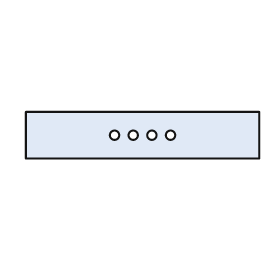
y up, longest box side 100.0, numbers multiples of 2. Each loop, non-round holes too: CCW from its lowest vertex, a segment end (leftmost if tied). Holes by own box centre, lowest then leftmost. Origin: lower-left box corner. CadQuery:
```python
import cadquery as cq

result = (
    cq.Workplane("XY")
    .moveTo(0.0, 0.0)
    .lineTo(100.0, 0.0)
    .lineTo(100.0, 20.0)
    .lineTo(0.0, 20.0)
    .close()
    .moveTo(38.0, 10.0)
    .circle(2.0)
    .moveTo(46.0, 10.0)
    .circle(2.0)
    .moveTo(54.0, 10.0)
    .circle(2.0)
    .moveTo(62.0, 10.0)
    .circle(2.0)
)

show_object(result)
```